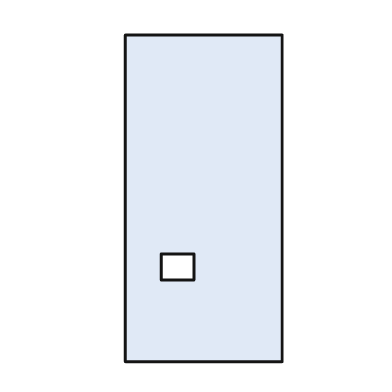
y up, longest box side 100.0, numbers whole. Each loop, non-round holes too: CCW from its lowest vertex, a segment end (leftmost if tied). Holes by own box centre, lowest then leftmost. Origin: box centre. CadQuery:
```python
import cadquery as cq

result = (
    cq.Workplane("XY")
    .moveTo(-24.0, -50.0)
    .lineTo(24.0, -50.0)
    .lineTo(24.0, 50.0)
    .lineTo(-24.0, 50.0)
    .close()
    .moveTo(-13.0, -25.0)
    .lineTo(-3.0, -25.0)
    .lineTo(-3.0, -17.0)
    .lineTo(-13.0, -17.0)
    .close()
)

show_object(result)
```